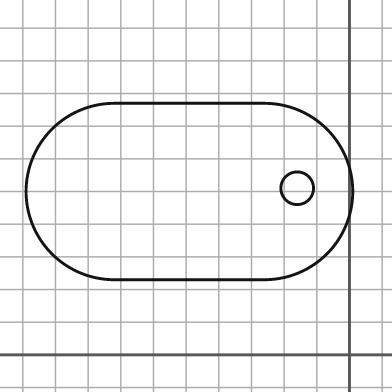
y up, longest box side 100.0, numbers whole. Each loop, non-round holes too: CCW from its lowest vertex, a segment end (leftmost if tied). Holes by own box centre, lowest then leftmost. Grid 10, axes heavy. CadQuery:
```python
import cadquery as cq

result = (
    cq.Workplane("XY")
    .moveTo(-72.0, 23.0)
    .lineTo(-26.0, 23.0)
    .threePointArc((1.0, 50.0), (-26.0, 77.0))
    .lineTo(-72.0, 77.0)
    .threePointArc((-99.0, 50.0), (-72.0, 23.0))
    .close()
    .moveTo(-16.0, 51.0)
    .circle(5.0)
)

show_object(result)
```